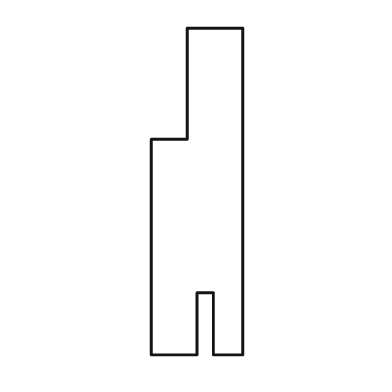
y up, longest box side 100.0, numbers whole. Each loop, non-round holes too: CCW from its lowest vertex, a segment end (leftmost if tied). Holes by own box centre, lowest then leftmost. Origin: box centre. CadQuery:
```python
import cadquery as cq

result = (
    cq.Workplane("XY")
    .moveTo(-14.0, -50.0)
    .lineTo(0.0, -50.0)
    .lineTo(0.0, -31.0)
    .lineTo(5.0, -31.0)
    .lineTo(5.0, -50.0)
    .lineTo(14.0, -50.0)
    .lineTo(14.0, 50.0)
    .lineTo(-3.0, 50.0)
    .lineTo(-3.0, 16.0)
    .lineTo(-14.0, 16.0)
    .close()
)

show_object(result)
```